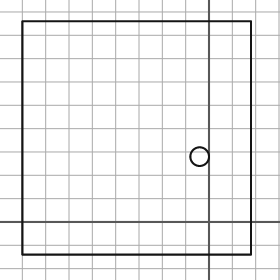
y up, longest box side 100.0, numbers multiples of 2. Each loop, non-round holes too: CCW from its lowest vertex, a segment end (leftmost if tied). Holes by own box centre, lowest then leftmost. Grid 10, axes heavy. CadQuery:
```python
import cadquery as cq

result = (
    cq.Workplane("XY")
    .moveTo(-80.0, -14.0)
    .lineTo(18.0, -14.0)
    .lineTo(18.0, 86.0)
    .lineTo(-80.0, 86.0)
    .close()
    .moveTo(-4.0, 28.0)
    .circle(4.0)
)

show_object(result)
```